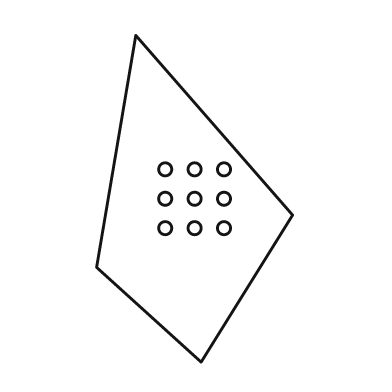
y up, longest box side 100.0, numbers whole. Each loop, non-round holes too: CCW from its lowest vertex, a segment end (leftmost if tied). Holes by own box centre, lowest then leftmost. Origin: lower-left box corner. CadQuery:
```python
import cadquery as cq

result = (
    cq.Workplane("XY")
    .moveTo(32.0, 0.0)
    .lineTo(60.0, 45.0)
    .lineTo(12.0, 100.0)
    .lineTo(0.0, 29.0)
    .close()
    .moveTo(21.0, 41.0)
    .circle(2.0)
    .moveTo(30.0, 41.0)
    .circle(2.0)
    .moveTo(39.0, 41.0)
    .circle(2.0)
    .moveTo(21.0, 50.0)
    .circle(2.0)
    .moveTo(30.0, 50.0)
    .circle(2.0)
    .moveTo(39.0, 50.0)
    .circle(2.0)
    .moveTo(21.0, 59.0)
    .circle(2.0)
    .moveTo(30.0, 59.0)
    .circle(2.0)
    .moveTo(39.0, 59.0)
    .circle(2.0)
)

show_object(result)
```